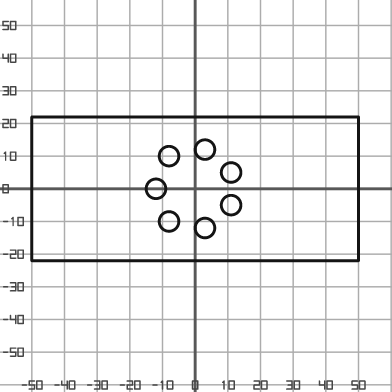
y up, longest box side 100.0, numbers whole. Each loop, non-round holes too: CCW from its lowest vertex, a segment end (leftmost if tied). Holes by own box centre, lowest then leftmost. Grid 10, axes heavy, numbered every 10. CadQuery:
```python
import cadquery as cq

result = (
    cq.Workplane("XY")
    .moveTo(-50.0, -22.0)
    .lineTo(50.0, -22.0)
    .lineTo(50.0, 22.0)
    .lineTo(-50.0, 22.0)
    .close()
    .moveTo(3.0, -12.0)
    .circle(3.0)
    .moveTo(-8.0, -10.0)
    .circle(3.0)
    .moveTo(11.0, -5.0)
    .circle(3.0)
    .moveTo(-12.0, 0.0)
    .circle(3.0)
    .moveTo(11.0, 5.0)
    .circle(3.0)
    .moveTo(-8.0, 10.0)
    .circle(3.0)
    .moveTo(3.0, 12.0)
    .circle(3.0)
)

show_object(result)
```